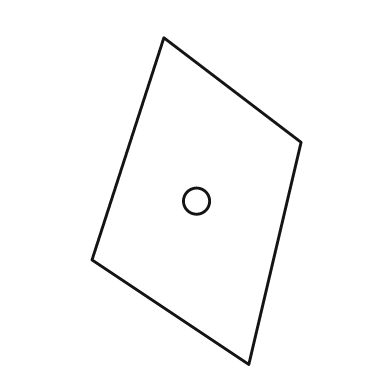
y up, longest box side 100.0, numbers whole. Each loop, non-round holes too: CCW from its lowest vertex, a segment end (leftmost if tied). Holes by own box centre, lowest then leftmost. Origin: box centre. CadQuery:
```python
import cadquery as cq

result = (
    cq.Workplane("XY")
    .moveTo(16.0, -50.0)
    .lineTo(32.0, 18.0)
    .lineTo(-10.0, 50.0)
    .lineTo(-32.0, -18.0)
    .close()
    .moveTo(0.0, 0.0)
    .circle(4.0)
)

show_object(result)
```